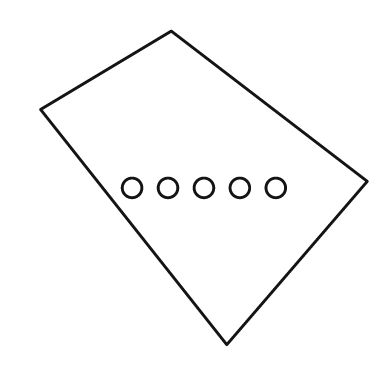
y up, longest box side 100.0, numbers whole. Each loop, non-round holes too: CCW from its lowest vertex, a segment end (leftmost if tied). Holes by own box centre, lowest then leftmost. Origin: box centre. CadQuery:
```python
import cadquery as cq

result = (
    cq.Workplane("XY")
    .moveTo(7.0, -48.0)
    .lineTo(50.0, 2.0)
    .lineTo(-10.0, 48.0)
    .lineTo(-50.0, 24.0)
    .close()
    .moveTo(-22.0, 0.0)
    .circle(3.0)
    .moveTo(-11.0, 0.0)
    .circle(3.0)
    .moveTo(0.0, 0.0)
    .circle(3.0)
    .moveTo(11.0, 0.0)
    .circle(3.0)
    .moveTo(22.0, 0.0)
    .circle(3.0)
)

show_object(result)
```